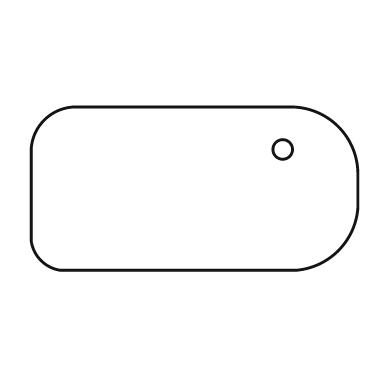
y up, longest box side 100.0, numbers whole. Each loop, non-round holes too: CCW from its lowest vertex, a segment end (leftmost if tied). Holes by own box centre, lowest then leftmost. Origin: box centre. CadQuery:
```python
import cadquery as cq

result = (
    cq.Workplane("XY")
    .moveTo(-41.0, -25.0)
    .lineTo(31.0, -25.0)
    .threePointArc((44.0, -19.0), (50.0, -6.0))
    .lineTo(50.0, 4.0)
    .threePointArc((44.0, 19.0), (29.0, 25.0))
    .lineTo(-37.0, 25.0)
    .threePointArc((-46.0, 21.0), (-50.0, 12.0))
    .lineTo(-50.0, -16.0)
    .threePointArc((-47.0, -22.0), (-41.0, -25.0))
    .close()
    .moveTo(27.0, 12.0)
    .circle(3.0)
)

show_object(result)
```